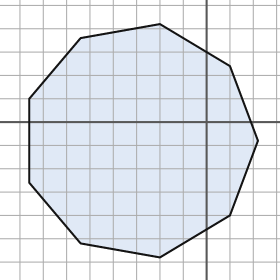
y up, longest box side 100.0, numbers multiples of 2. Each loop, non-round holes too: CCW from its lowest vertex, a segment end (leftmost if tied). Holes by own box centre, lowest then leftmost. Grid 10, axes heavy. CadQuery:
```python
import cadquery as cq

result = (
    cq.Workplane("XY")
    .moveTo(-20.0, -58.0)
    .lineTo(10.0, -40.0)
    .lineTo(22.0, -8.0)
    .lineTo(10.0, 24.0)
    .lineTo(-20.0, 42.0)
    .lineTo(-54.0, 36.0)
    .lineTo(-76.0, 10.0)
    .lineTo(-76.0, -26.0)
    .lineTo(-54.0, -52.0)
    .close()
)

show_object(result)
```